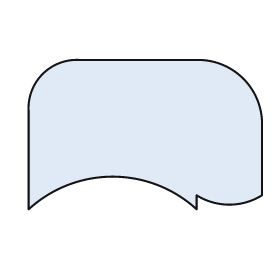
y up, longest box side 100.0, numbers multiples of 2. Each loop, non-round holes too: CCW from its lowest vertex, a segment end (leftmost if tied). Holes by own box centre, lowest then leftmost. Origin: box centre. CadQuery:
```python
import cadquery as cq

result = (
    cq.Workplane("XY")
    .moveTo(-50.0, -32.0)
    .threePointArc((-14.0, -18.0), (22.0, -32.0))
    .lineTo(22.0, -26.0)
    .threePointArc((36.0, -30.0), (50.0, -26.0))
    .lineTo(50.0, 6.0)
    .threePointArc((42.0, 24.0), (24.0, 32.0))
    .lineTo(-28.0, 32.0)
    .threePointArc((-44.0, 26.0), (-50.0, 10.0))
    .close()
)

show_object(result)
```